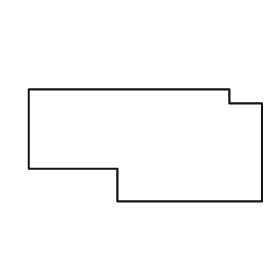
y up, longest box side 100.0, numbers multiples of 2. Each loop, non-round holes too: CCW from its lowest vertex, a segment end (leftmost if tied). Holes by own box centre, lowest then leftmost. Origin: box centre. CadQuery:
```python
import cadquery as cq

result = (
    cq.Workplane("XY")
    .moveTo(-12.0, -24.0)
    .lineTo(50.0, -24.0)
    .lineTo(50.0, 18.0)
    .lineTo(36.0, 18.0)
    .lineTo(36.0, 24.0)
    .lineTo(-50.0, 24.0)
    .lineTo(-50.0, -10.0)
    .lineTo(-12.0, -10.0)
    .close()
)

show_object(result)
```